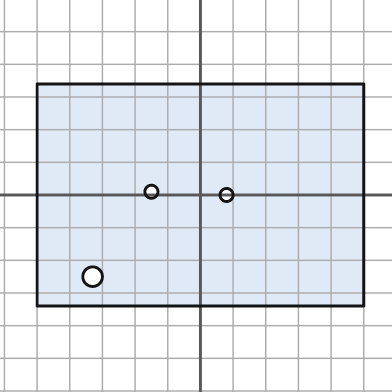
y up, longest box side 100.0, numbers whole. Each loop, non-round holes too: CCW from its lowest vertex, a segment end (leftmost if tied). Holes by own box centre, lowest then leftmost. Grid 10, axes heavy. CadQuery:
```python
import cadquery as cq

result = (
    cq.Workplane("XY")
    .moveTo(-50.0, -34.0)
    .lineTo(50.0, -34.0)
    .lineTo(50.0, 34.0)
    .lineTo(-50.0, 34.0)
    .close()
    .moveTo(-33.0, -25.0)
    .circle(3.0)
    .moveTo(8.0, 0.0)
    .circle(2.0)
    .moveTo(-15.0, 1.0)
    .circle(2.0)
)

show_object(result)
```